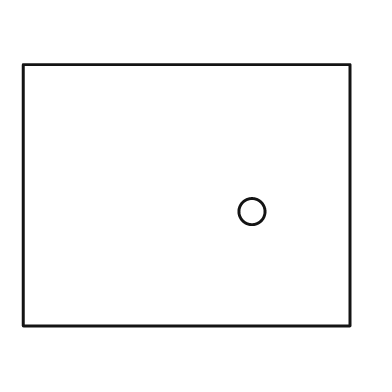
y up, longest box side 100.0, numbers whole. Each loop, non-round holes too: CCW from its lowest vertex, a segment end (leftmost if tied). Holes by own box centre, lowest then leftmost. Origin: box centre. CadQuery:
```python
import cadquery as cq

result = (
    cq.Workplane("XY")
    .moveTo(-50.0, -40.0)
    .lineTo(50.0, -40.0)
    .lineTo(50.0, 40.0)
    .lineTo(-50.0, 40.0)
    .close()
    .moveTo(20.0, -5.0)
    .circle(4.0)
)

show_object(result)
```